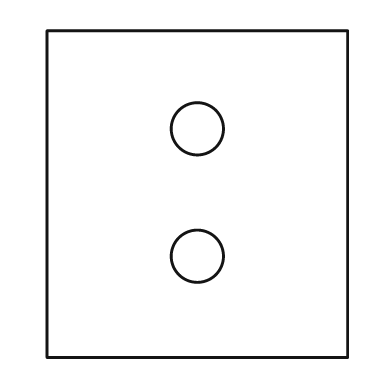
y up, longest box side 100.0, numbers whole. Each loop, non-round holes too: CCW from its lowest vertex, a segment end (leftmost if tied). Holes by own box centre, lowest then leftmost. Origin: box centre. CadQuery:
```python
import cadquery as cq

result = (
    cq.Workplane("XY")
    .moveTo(-46.0, -50.0)
    .lineTo(46.0, -50.0)
    .lineTo(46.0, 50.0)
    .lineTo(-46.0, 50.0)
    .close()
    .moveTo(0.0, -19.0)
    .circle(8.0)
    .moveTo(0.0, 20.0)
    .circle(8.0)
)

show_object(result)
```